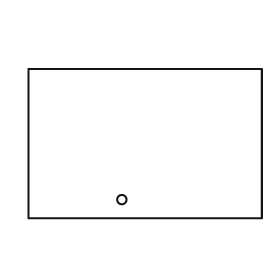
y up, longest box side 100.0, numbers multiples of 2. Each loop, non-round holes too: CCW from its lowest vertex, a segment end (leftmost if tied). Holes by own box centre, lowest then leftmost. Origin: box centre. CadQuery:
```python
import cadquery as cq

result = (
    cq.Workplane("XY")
    .moveTo(-50.0, -32.0)
    .lineTo(50.0, -32.0)
    .lineTo(50.0, 32.0)
    .lineTo(-50.0, 32.0)
    .close()
    .moveTo(-10.0, -24.0)
    .circle(2.0)
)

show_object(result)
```